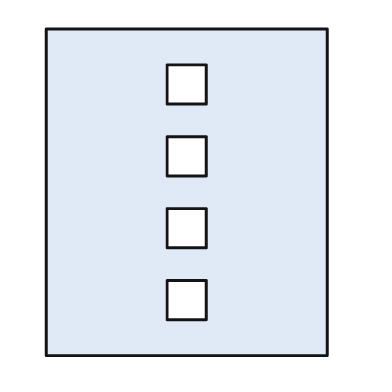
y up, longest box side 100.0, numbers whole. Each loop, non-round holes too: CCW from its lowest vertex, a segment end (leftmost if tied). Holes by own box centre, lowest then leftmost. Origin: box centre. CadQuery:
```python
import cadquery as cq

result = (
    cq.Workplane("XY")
    .moveTo(-43.0, -50.0)
    .lineTo(43.0, -50.0)
    .lineTo(43.0, 50.0)
    .lineTo(-43.0, 50.0)
    .close()
    .moveTo(-6.0, -39.0)
    .lineTo(6.0, -39.0)
    .lineTo(6.0, -27.0)
    .lineTo(-6.0, -27.0)
    .close()
    .moveTo(-6.0, -17.0)
    .lineTo(6.0, -17.0)
    .lineTo(6.0, -5.0)
    .lineTo(-6.0, -5.0)
    .close()
    .moveTo(-6.0, 5.0)
    .lineTo(6.0, 5.0)
    .lineTo(6.0, 17.0)
    .lineTo(-6.0, 17.0)
    .close()
    .moveTo(-6.0, 27.0)
    .lineTo(6.0, 27.0)
    .lineTo(6.0, 39.0)
    .lineTo(-6.0, 39.0)
    .close()
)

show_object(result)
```